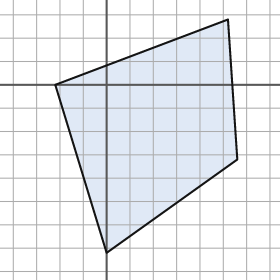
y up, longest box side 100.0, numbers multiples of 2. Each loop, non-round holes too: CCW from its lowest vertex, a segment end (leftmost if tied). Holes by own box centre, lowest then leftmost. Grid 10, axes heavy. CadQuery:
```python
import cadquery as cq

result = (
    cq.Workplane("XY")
    .moveTo(0.0, -72.0)
    .lineTo(56.0, -32.0)
    .lineTo(52.0, 28.0)
    .lineTo(-22.0, 0.0)
    .close()
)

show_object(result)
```